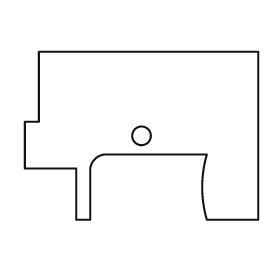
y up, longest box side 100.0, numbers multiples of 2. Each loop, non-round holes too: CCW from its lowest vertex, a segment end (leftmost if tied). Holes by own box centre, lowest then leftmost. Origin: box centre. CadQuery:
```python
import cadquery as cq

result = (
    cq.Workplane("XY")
    .moveTo(-28.0, -36.0)
    .lineTo(-22.0, -36.0)
    .lineTo(-22.0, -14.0)
    .threePointArc((-20.0, -10.0), (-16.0, -8.0))
    .lineTo(28.0, -8.0)
    .threePointArc((26.0, -22.0), (28.0, -36.0))
    .lineTo(50.0, -36.0)
    .lineTo(50.0, 36.0)
    .lineTo(-44.0, 36.0)
    .lineTo(-44.0, 6.0)
    .lineTo(-50.0, 6.0)
    .lineTo(-50.0, -14.0)
    .lineTo(-28.0, -14.0)
    .close()
    .moveTo(0.0, 0.0)
    .circle(4.0)
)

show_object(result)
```